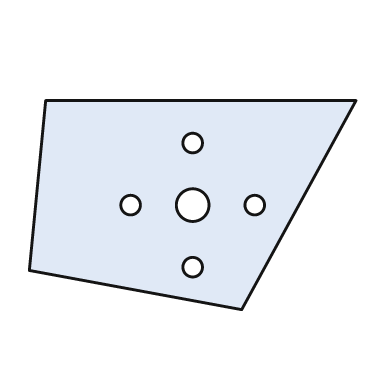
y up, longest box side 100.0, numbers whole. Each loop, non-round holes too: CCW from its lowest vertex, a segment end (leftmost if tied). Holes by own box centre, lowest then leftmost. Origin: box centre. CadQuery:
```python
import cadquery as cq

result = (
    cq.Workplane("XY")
    .moveTo(15.0, -32.0)
    .lineTo(50.0, 32.0)
    .lineTo(-45.0, 32.0)
    .lineTo(-50.0, -20.0)
    .close()
    .moveTo(0.0, -19.0)
    .circle(3.0)
    .moveTo(-19.0, 0.0)
    .circle(3.0)
    .moveTo(0.0, 0.0)
    .circle(5.0)
    .moveTo(19.0, 0.0)
    .circle(3.0)
    .moveTo(0.0, 19.0)
    .circle(3.0)
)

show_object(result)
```